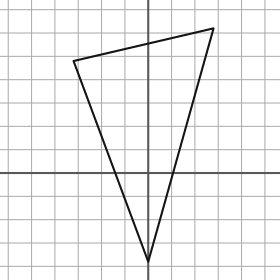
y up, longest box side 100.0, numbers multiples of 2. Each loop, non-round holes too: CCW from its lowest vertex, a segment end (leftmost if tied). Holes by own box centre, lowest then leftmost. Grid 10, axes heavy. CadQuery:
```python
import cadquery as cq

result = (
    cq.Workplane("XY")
    .moveTo(0.0, -38.0)
    .lineTo(28.0, 62.0)
    .lineTo(-32.0, 48.0)
    .close()
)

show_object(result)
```